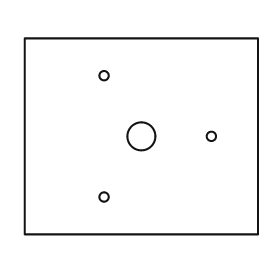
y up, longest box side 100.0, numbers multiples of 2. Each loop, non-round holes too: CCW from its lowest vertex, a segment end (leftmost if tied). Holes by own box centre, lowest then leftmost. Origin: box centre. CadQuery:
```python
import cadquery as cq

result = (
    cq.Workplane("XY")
    .moveTo(-50.0, -42.0)
    .lineTo(50.0, -42.0)
    .lineTo(50.0, 42.0)
    .lineTo(-50.0, 42.0)
    .close()
    .moveTo(-16.0, -26.0)
    .circle(2.0)
    .moveTo(0.0, 0.0)
    .circle(6.0)
    .moveTo(30.0, 0.0)
    .circle(2.0)
    .moveTo(-16.0, 26.0)
    .circle(2.0)
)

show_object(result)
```